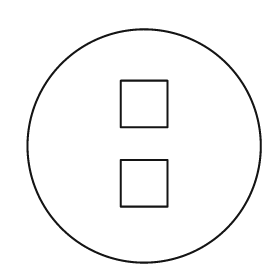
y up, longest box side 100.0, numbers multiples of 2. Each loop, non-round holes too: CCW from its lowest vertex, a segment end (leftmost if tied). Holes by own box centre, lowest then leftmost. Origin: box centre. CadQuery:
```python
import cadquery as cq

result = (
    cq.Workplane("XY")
    .moveTo(0.0, 0.0)
    .circle(50.0)
    .moveTo(-10.0, -26.0)
    .lineTo(10.0, -26.0)
    .lineTo(10.0, -6.0)
    .lineTo(-10.0, -6.0)
    .close()
    .moveTo(-10.0, 8.0)
    .lineTo(10.0, 8.0)
    .lineTo(10.0, 28.0)
    .lineTo(-10.0, 28.0)
    .close()
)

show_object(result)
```